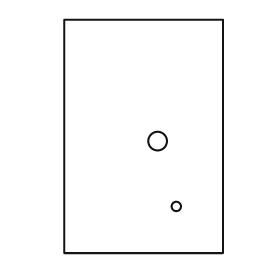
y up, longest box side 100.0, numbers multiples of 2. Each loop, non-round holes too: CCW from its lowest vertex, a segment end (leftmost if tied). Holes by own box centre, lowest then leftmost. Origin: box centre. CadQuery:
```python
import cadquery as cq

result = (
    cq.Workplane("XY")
    .moveTo(-34.0, -50.0)
    .lineTo(34.0, -50.0)
    .lineTo(34.0, 50.0)
    .lineTo(-34.0, 50.0)
    .close()
    .moveTo(14.0, -30.0)
    .circle(2.0)
    .moveTo(6.0, -2.0)
    .circle(4.0)
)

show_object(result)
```